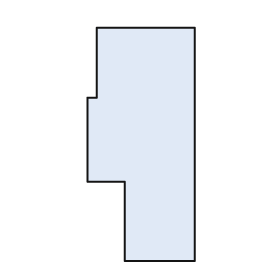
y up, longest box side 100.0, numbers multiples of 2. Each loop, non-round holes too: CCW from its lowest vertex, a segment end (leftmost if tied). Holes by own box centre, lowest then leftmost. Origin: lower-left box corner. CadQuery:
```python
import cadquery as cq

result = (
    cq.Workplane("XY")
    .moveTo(16.0, 0.0)
    .lineTo(46.0, 0.0)
    .lineTo(46.0, 100.0)
    .lineTo(4.0, 100.0)
    .lineTo(4.0, 70.0)
    .lineTo(0.0, 70.0)
    .lineTo(0.0, 34.0)
    .lineTo(16.0, 34.0)
    .close()
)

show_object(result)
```